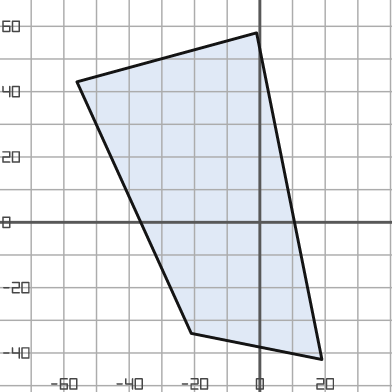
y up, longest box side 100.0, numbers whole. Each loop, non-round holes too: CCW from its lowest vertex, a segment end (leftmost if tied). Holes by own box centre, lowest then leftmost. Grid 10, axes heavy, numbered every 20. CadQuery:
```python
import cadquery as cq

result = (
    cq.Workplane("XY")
    .moveTo(19.0, -42.0)
    .lineTo(-1.0, 58.0)
    .lineTo(-56.0, 43.0)
    .lineTo(-21.0, -34.0)
    .close()
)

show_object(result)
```